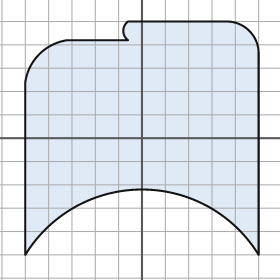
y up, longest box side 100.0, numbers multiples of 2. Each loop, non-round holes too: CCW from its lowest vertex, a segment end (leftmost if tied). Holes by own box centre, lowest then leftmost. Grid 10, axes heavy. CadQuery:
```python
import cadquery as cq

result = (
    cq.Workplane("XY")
    .moveTo(-50.0, -50.0)
    .threePointArc((0.0, -22.0), (50.0, -50.0))
    .lineTo(50.0, 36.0)
    .threePointArc((46.0, 46.0), (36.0, 50.0))
    .lineTo(-6.0, 50.0)
    .threePointArc((-8.0, 46.0), (-6.0, 42.0))
    .lineTo(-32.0, 42.0)
    .threePointArc((-44.0, 36.0), (-50.0, 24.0))
    .close()
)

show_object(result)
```